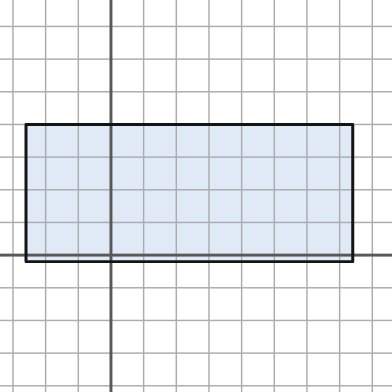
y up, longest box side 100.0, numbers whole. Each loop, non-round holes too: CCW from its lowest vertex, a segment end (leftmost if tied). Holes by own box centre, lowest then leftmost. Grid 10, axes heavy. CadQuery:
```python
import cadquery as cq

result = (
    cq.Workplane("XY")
    .moveTo(-26.0, -2.0)
    .lineTo(74.0, -2.0)
    .lineTo(74.0, 40.0)
    .lineTo(-26.0, 40.0)
    .close()
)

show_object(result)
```